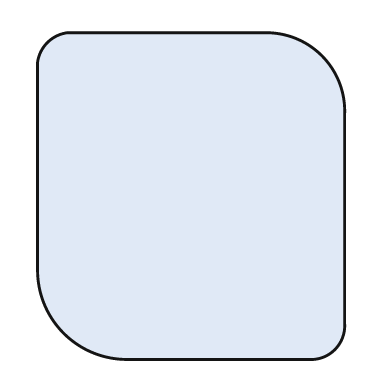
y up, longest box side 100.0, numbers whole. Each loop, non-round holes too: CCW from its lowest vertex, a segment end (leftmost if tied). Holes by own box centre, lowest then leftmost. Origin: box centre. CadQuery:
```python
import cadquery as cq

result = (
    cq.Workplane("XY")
    .moveTo(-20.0, -50.0)
    .lineTo(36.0, -50.0)
    .threePointArc((44.0, -47.0), (47.0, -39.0))
    .lineTo(47.0, 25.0)
    .threePointArc((40.0, 43.0), (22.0, 50.0))
    .lineTo(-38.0, 50.0)
    .threePointArc((-44.0, 47.0), (-47.0, 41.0))
    .lineTo(-47.0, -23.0)
    .threePointArc((-39.0, -42.0), (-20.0, -50.0))
    .close()
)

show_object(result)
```